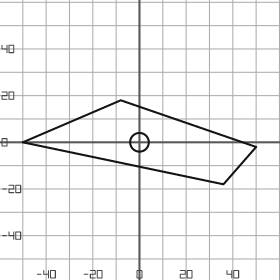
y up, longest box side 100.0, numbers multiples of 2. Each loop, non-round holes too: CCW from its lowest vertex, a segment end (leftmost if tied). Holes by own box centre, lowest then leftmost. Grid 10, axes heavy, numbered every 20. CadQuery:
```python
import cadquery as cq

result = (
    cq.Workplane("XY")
    .moveTo(36.0, -18.0)
    .lineTo(50.0, -2.0)
    .lineTo(-8.0, 18.0)
    .lineTo(-50.0, 0.0)
    .close()
    .moveTo(0.0, 0.0)
    .circle(4.0)
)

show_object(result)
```